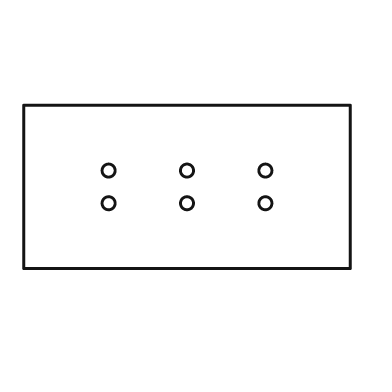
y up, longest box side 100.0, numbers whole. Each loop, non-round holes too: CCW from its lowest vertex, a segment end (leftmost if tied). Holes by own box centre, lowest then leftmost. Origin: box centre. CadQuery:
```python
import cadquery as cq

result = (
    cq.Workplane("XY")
    .moveTo(-50.0, -25.0)
    .lineTo(50.0, -25.0)
    .lineTo(50.0, 25.0)
    .lineTo(-50.0, 25.0)
    .close()
    .moveTo(-24.0, -5.0)
    .circle(2.0)
    .moveTo(0.0, -5.0)
    .circle(2.0)
    .moveTo(24.0, -5.0)
    .circle(2.0)
    .moveTo(-24.0, 5.0)
    .circle(2.0)
    .moveTo(0.0, 5.0)
    .circle(2.0)
    .moveTo(24.0, 5.0)
    .circle(2.0)
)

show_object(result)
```